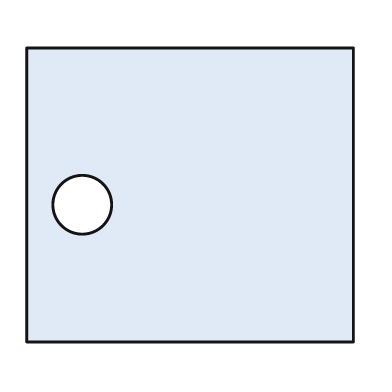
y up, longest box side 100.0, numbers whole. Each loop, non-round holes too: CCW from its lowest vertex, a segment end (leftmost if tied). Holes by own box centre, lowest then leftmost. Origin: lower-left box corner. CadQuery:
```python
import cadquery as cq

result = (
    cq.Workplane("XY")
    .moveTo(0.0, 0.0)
    .lineTo(100.0, 0.0)
    .lineTo(100.0, 90.0)
    .lineTo(0.0, 90.0)
    .close()
    .moveTo(17.0, 42.0)
    .circle(9.0)
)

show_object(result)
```